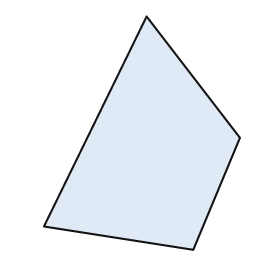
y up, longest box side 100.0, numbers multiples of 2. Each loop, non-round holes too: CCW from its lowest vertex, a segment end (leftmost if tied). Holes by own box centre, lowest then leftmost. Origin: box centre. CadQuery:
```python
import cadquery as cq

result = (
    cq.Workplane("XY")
    .moveTo(22.0, -50.0)
    .lineTo(42.0, -2.0)
    .lineTo(2.0, 50.0)
    .lineTo(-42.0, -40.0)
    .close()
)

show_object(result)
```